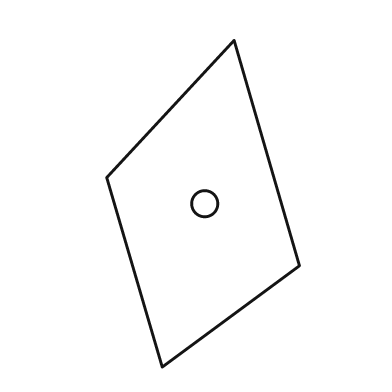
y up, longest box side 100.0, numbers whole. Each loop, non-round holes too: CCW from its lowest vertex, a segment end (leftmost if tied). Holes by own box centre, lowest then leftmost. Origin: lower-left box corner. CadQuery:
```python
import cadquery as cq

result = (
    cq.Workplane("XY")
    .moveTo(17.0, 0.0)
    .lineTo(59.0, 31.0)
    .lineTo(39.0, 100.0)
    .lineTo(0.0, 58.0)
    .close()
    .moveTo(30.0, 50.0)
    .circle(4.0)
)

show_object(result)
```